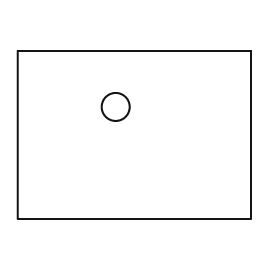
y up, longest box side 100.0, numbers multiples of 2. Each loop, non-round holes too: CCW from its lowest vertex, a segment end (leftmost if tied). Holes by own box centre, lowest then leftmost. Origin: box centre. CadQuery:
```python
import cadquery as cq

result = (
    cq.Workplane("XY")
    .moveTo(-50.0, -36.0)
    .lineTo(50.0, -36.0)
    .lineTo(50.0, 36.0)
    .lineTo(-50.0, 36.0)
    .close()
    .moveTo(-8.0, 12.0)
    .circle(6.0)
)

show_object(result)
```